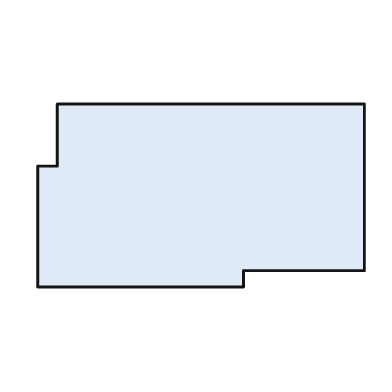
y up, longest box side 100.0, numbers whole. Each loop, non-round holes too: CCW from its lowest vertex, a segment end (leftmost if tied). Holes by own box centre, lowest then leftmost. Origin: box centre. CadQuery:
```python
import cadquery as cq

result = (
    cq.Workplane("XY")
    .moveTo(-50.0, -28.0)
    .lineTo(13.0, -28.0)
    .lineTo(13.0, -23.0)
    .lineTo(50.0, -23.0)
    .lineTo(50.0, 28.0)
    .lineTo(-44.0, 28.0)
    .lineTo(-44.0, 9.0)
    .lineTo(-50.0, 9.0)
    .close()
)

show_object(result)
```